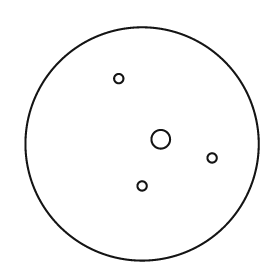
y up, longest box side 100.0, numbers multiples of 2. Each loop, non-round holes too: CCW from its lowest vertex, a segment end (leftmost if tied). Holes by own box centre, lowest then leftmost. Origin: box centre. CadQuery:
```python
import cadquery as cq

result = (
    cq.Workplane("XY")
    .moveTo(0.0, 0.0)
    .circle(50.0)
    .moveTo(0.0, -18.0)
    .circle(2.0)
    .moveTo(30.0, -6.0)
    .circle(2.0)
    .moveTo(8.0, 2.0)
    .circle(4.0)
    .moveTo(-10.0, 28.0)
    .circle(2.0)
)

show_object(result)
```